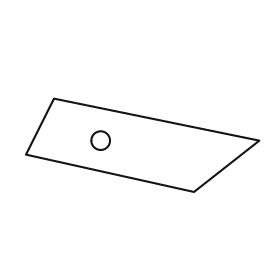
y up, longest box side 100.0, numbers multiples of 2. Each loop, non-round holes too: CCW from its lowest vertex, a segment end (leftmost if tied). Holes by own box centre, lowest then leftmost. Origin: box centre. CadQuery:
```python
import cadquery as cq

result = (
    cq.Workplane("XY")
    .moveTo(22.0, -20.0)
    .lineTo(50.0, 2.0)
    .lineTo(-38.0, 20.0)
    .lineTo(-50.0, -4.0)
    .close()
    .moveTo(-18.0, 2.0)
    .circle(4.0)
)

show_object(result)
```